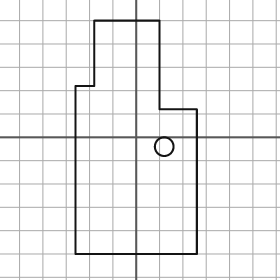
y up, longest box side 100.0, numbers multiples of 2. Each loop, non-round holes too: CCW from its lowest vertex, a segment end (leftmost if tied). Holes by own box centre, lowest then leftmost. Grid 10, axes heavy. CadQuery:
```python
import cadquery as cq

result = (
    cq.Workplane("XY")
    .moveTo(-26.0, -50.0)
    .lineTo(26.0, -50.0)
    .lineTo(26.0, 12.0)
    .lineTo(10.0, 12.0)
    .lineTo(10.0, 50.0)
    .lineTo(-18.0, 50.0)
    .lineTo(-18.0, 22.0)
    .lineTo(-26.0, 22.0)
    .close()
    .moveTo(12.0, -4.0)
    .circle(4.0)
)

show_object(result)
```